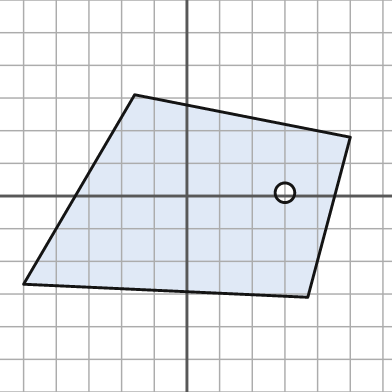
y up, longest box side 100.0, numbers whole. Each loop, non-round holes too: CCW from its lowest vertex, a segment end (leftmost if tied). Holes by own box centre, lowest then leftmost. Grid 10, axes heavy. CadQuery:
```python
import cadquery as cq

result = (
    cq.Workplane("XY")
    .moveTo(37.0, -31.0)
    .lineTo(50.0, 18.0)
    .lineTo(-16.0, 31.0)
    .lineTo(-50.0, -27.0)
    .close()
    .moveTo(30.0, 1.0)
    .circle(3.0)
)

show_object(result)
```